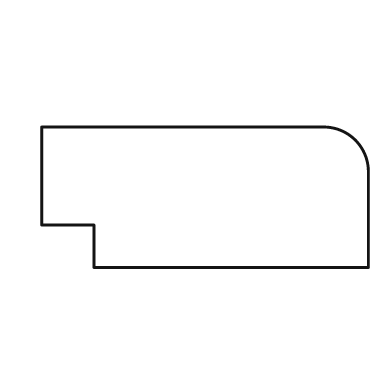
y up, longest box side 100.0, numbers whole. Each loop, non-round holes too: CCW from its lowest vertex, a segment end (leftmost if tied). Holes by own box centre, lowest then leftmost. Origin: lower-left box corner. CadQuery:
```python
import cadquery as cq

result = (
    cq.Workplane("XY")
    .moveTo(16.0, 0.0)
    .lineTo(100.0, 0.0)
    .lineTo(100.0, 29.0)
    .threePointArc((96.0, 39.0), (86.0, 43.0))
    .lineTo(0.0, 43.0)
    .lineTo(0.0, 13.0)
    .lineTo(16.0, 13.0)
    .close()
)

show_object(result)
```